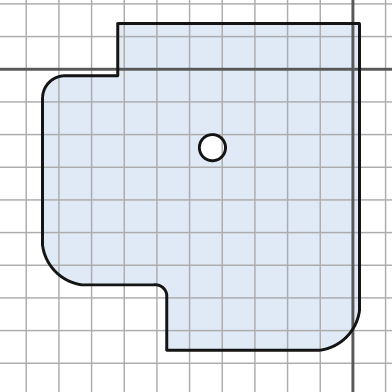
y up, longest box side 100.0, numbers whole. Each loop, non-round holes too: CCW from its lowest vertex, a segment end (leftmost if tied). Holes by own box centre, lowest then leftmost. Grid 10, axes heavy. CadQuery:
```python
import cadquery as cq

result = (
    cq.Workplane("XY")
    .moveTo(-57.0, -86.0)
    .lineTo(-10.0, -86.0)
    .threePointArc((-2.0, -82.0), (2.0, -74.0))
    .lineTo(2.0, 14.0)
    .lineTo(-72.0, 14.0)
    .lineTo(-72.0, -2.0)
    .lineTo(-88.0, -2.0)
    .threePointArc((-93.0, -4.0), (-95.0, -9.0))
    .lineTo(-95.0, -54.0)
    .threePointArc((-91.0, -62.0), (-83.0, -66.0))
    .lineTo(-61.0, -66.0)
    .threePointArc((-58.0, -67.0), (-57.0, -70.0))
    .close()
    .moveTo(-43.0, -24.0)
    .circle(4.0)
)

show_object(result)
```